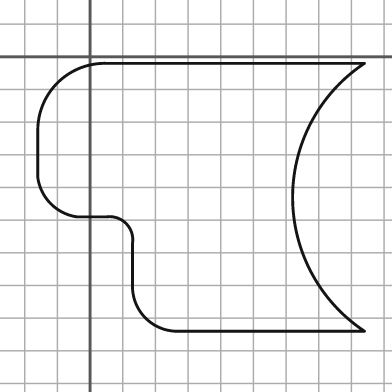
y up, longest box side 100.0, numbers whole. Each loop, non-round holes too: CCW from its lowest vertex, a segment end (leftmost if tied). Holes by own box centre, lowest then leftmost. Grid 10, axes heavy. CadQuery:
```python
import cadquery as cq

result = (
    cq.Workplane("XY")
    .moveTo(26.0, -84.0)
    .lineTo(84.0, -84.0)
    .threePointArc((62.0, -43.0), (84.0, -2.0))
    .lineTo(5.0, -2.0)
    .threePointArc((-10.0, -8.0), (-16.0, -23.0))
    .lineTo(-16.0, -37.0)
    .threePointArc((-12.0, -45.0), (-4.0, -49.0))
    .lineTo(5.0, -49.0)
    .threePointArc((11.0, -51.0), (13.0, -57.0))
    .lineTo(13.0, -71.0)
    .threePointArc((17.0, -80.0), (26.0, -84.0))
    .close()
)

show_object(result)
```